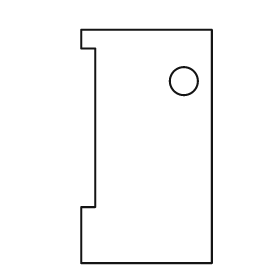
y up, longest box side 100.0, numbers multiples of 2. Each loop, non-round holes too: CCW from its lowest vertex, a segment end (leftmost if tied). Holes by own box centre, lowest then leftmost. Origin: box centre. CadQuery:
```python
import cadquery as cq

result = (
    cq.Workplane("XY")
    .moveTo(-28.0, -50.0)
    .lineTo(28.0, -50.0)
    .lineTo(28.0, 50.0)
    .lineTo(-28.0, 50.0)
    .lineTo(-28.0, 42.0)
    .lineTo(-22.0, 42.0)
    .lineTo(-22.0, -26.0)
    .lineTo(-28.0, -26.0)
    .close()
    .moveTo(16.0, 28.0)
    .circle(6.0)
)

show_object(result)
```